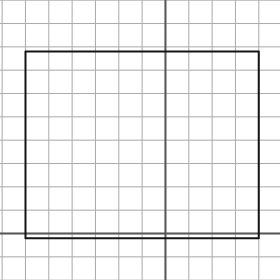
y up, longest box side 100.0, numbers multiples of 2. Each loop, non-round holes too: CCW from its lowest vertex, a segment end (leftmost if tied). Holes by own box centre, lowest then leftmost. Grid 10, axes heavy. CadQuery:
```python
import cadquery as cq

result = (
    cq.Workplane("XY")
    .moveTo(-60.0, -2.0)
    .lineTo(40.0, -2.0)
    .lineTo(40.0, 78.0)
    .lineTo(-60.0, 78.0)
    .close()
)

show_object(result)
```